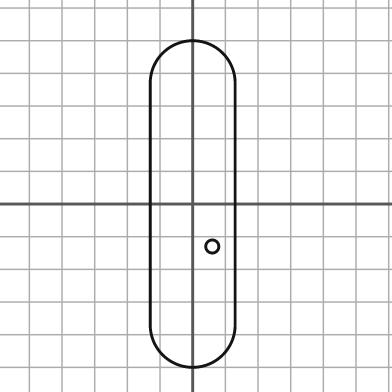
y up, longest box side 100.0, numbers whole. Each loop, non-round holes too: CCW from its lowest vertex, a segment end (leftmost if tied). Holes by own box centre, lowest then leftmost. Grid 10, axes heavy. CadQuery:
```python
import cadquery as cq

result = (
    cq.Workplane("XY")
    .moveTo(-13.0, -37.0)
    .threePointArc((0.0, -50.0), (13.0, -37.0))
    .lineTo(13.0, 37.0)
    .threePointArc((0.0, 50.0), (-13.0, 37.0))
    .close()
    .moveTo(6.0, -13.0)
    .circle(2.0)
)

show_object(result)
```